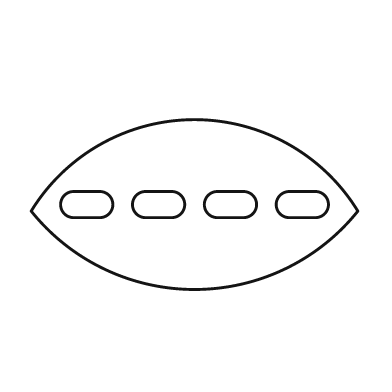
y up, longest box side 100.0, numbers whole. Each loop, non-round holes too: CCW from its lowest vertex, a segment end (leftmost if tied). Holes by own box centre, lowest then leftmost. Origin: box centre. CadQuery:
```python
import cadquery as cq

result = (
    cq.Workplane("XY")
    .moveTo(-50.0, -2.0)
    .threePointArc((0.0, -26.0), (50.0, -2.0))
    .threePointArc((0.0, 26.0), (-50.0, -2.0))
    .close()
    .moveTo(-37.0, -4.0)
    .lineTo(-29.0, -4.0)
    .threePointArc((-25.0, 0.0), (-29.0, 4.0))
    .lineTo(-37.0, 4.0)
    .threePointArc((-41.0, 0.0), (-37.0, -4.0))
    .close()
    .moveTo(-15.0, -4.0)
    .lineTo(-7.0, -4.0)
    .threePointArc((-3.0, 0.0), (-7.0, 4.0))
    .lineTo(-15.0, 4.0)
    .threePointArc((-19.0, 0.0), (-15.0, -4.0))
    .close()
    .moveTo(7.0, -4.0)
    .lineTo(15.0, -4.0)
    .threePointArc((19.0, 0.0), (15.0, 4.0))
    .lineTo(7.0, 4.0)
    .threePointArc((3.0, 0.0), (7.0, -4.0))
    .close()
    .moveTo(29.0, -4.0)
    .lineTo(37.0, -4.0)
    .threePointArc((41.0, 0.0), (37.0, 4.0))
    .lineTo(29.0, 4.0)
    .threePointArc((25.0, 0.0), (29.0, -4.0))
    .close()
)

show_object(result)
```